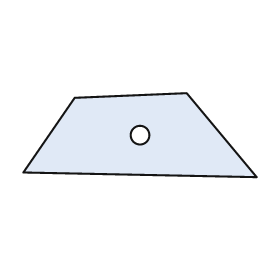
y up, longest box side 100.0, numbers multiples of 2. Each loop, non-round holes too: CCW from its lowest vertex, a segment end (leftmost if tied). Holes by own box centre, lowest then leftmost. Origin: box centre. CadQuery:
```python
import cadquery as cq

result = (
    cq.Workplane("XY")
    .moveTo(50.0, -18.0)
    .lineTo(20.0, 18.0)
    .lineTo(-28.0, 16.0)
    .lineTo(-50.0, -16.0)
    .close()
    .moveTo(0.0, 0.0)
    .circle(4.0)
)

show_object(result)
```